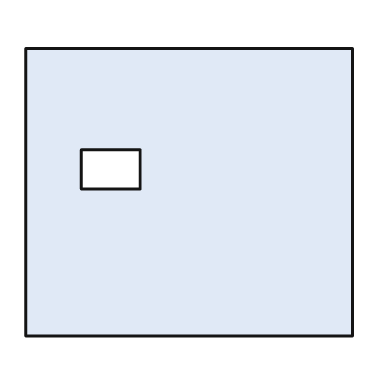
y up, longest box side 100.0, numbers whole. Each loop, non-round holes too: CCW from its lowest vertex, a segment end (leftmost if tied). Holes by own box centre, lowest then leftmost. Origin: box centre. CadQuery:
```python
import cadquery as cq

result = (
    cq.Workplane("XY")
    .moveTo(-50.0, -44.0)
    .lineTo(50.0, -44.0)
    .lineTo(50.0, 44.0)
    .lineTo(-50.0, 44.0)
    .close()
    .moveTo(-33.0, 1.0)
    .lineTo(-15.0, 1.0)
    .lineTo(-15.0, 13.0)
    .lineTo(-33.0, 13.0)
    .close()
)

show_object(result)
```